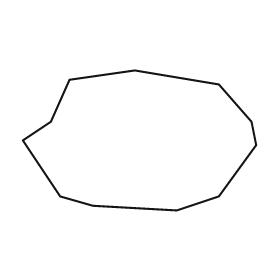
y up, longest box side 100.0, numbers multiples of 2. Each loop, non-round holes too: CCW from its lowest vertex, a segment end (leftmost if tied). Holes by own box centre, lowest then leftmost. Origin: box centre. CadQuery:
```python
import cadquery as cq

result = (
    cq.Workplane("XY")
    .moveTo(16.0, -30.0)
    .lineTo(34.0, -24.0)
    .lineTo(50.0, -2.0)
    .lineTo(48.0, 8.0)
    .lineTo(34.0, 24.0)
    .lineTo(-2.0, 30.0)
    .lineTo(-30.0, 26.0)
    .lineTo(-38.0, 8.0)
    .lineTo(-50.0, 0.0)
    .lineTo(-34.0, -24.0)
    .lineTo(-20.0, -28.0)
    .close()
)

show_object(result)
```